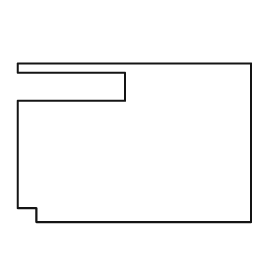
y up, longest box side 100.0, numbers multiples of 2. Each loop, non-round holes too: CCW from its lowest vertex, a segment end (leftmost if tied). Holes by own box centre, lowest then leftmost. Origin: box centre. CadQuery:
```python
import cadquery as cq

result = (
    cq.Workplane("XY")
    .moveTo(-42.0, -34.0)
    .lineTo(50.0, -34.0)
    .lineTo(50.0, 34.0)
    .lineTo(-50.0, 34.0)
    .lineTo(-50.0, 30.0)
    .lineTo(-4.0, 30.0)
    .lineTo(-4.0, 18.0)
    .lineTo(-50.0, 18.0)
    .lineTo(-50.0, -28.0)
    .lineTo(-42.0, -28.0)
    .close()
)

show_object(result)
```